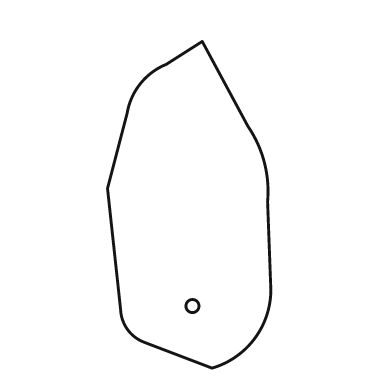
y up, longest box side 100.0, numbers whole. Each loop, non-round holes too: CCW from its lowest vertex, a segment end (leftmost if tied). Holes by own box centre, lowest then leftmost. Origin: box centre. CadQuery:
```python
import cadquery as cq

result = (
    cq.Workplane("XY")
    .moveTo(7.0, -50.0)
    .threePointArc((20.0, -41.0), (25.0, -26.0))
    .lineTo(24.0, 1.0)
    .threePointArc((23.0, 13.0), (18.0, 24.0))
    .lineTo(4.0, 50.0)
    .lineTo(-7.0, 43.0)
    .threePointArc((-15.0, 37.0), (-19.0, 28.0))
    .lineTo(-25.0, 5.0)
    .lineTo(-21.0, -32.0)
    .threePointArc((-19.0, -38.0), (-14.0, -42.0))
    .close()
    .moveTo(1.0, -31.0)
    .circle(2.0)
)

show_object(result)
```